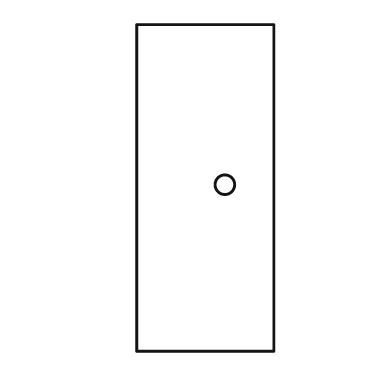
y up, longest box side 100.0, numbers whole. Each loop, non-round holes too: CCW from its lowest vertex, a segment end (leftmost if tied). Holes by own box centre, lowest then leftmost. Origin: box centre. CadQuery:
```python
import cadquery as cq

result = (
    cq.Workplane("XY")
    .moveTo(-21.0, -50.0)
    .lineTo(21.0, -50.0)
    .lineTo(21.0, 50.0)
    .lineTo(-21.0, 50.0)
    .close()
    .moveTo(6.0, 1.0)
    .circle(3.0)
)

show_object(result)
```